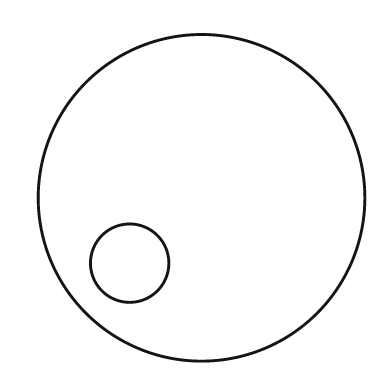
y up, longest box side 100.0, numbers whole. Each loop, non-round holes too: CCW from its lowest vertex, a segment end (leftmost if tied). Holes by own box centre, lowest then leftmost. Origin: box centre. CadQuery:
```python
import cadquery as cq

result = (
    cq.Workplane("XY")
    .moveTo(0.0, 0.0)
    .circle(50.0)
    .moveTo(-22.0, -20.0)
    .circle(12.0)
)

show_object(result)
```